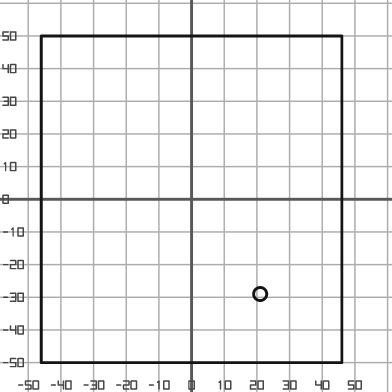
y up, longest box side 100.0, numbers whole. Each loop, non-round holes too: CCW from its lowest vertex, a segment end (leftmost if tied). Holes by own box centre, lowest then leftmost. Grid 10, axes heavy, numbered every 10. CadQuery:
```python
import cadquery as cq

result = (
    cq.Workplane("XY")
    .moveTo(-46.0, -50.0)
    .lineTo(46.0, -50.0)
    .lineTo(46.0, 50.0)
    .lineTo(-46.0, 50.0)
    .close()
    .moveTo(21.0, -29.0)
    .circle(2.0)
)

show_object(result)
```